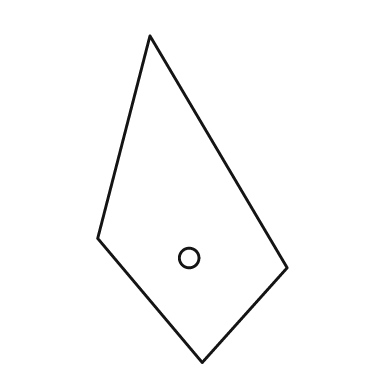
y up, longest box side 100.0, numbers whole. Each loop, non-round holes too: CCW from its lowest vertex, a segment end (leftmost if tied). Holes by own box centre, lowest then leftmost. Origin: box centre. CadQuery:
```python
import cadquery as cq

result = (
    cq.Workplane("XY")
    .moveTo(3.0, -50.0)
    .lineTo(29.0, -21.0)
    .lineTo(-13.0, 50.0)
    .lineTo(-29.0, -12.0)
    .close()
    .moveTo(-1.0, -18.0)
    .circle(3.0)
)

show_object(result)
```